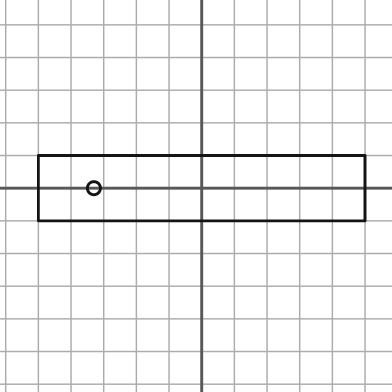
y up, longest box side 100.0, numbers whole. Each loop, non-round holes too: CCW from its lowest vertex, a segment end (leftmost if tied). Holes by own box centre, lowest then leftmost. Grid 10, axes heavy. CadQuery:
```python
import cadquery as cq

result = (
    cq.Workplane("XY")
    .moveTo(-50.0, -10.0)
    .lineTo(50.0, -10.0)
    .lineTo(50.0, 10.0)
    .lineTo(-50.0, 10.0)
    .close()
    .moveTo(-33.0, 0.0)
    .circle(2.0)
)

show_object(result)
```